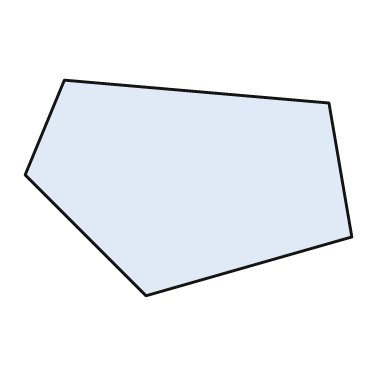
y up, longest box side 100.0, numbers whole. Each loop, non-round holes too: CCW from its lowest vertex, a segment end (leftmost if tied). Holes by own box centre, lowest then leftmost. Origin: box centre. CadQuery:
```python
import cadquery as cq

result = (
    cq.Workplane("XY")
    .moveTo(-13.0, -33.0)
    .lineTo(50.0, -15.0)
    .lineTo(43.0, 26.0)
    .lineTo(-38.0, 33.0)
    .lineTo(-50.0, 4.0)
    .close()
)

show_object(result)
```